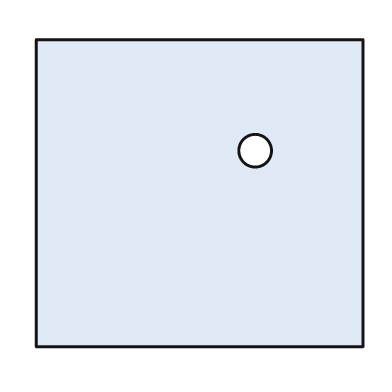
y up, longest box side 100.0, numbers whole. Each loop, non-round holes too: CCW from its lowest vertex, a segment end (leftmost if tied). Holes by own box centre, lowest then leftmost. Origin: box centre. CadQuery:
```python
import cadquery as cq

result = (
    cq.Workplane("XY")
    .moveTo(-50.0, -47.0)
    .lineTo(50.0, -47.0)
    .lineTo(50.0, 47.0)
    .lineTo(-50.0, 47.0)
    .close()
    .moveTo(17.0, 13.0)
    .circle(5.0)
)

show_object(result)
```